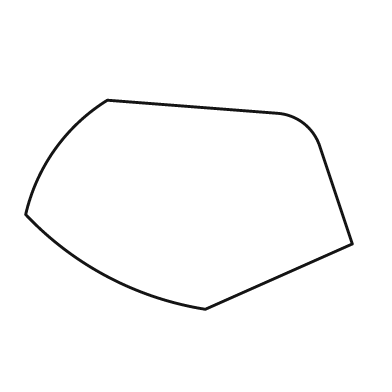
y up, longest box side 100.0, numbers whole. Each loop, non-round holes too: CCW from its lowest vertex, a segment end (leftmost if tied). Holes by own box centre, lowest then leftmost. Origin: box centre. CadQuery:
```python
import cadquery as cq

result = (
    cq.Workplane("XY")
    .moveTo(5.0, -32.0)
    .lineTo(50.0, -12.0)
    .lineTo(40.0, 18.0)
    .threePointArc((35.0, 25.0), (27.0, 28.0))
    .lineTo(-25.0, 32.0)
    .threePointArc((-41.0, 17.0), (-50.0, -3.0))
    .threePointArc((-25.0, -22.0), (5.0, -32.0))
    .close()
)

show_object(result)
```